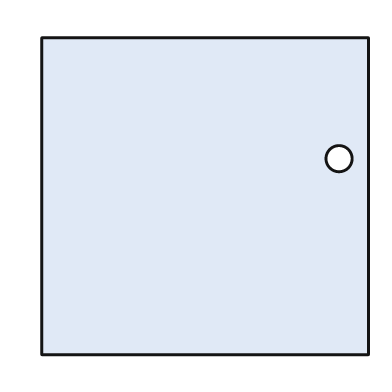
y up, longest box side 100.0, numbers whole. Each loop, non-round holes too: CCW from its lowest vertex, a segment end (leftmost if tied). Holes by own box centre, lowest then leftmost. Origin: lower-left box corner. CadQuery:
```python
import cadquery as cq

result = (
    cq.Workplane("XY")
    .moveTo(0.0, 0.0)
    .lineTo(100.0, 0.0)
    .lineTo(100.0, 97.0)
    .lineTo(0.0, 97.0)
    .close()
    .moveTo(91.0, 60.0)
    .circle(4.0)
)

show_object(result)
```